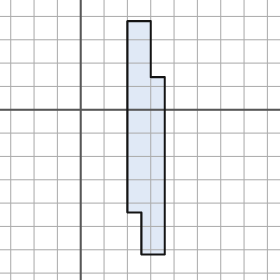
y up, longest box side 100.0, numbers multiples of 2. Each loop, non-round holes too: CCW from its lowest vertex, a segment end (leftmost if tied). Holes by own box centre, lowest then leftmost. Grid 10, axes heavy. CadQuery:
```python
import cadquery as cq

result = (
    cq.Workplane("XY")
    .moveTo(26.0, -62.0)
    .lineTo(36.0, -62.0)
    .lineTo(36.0, 14.0)
    .lineTo(30.0, 14.0)
    .lineTo(30.0, 38.0)
    .lineTo(20.0, 38.0)
    .lineTo(20.0, -44.0)
    .lineTo(26.0, -44.0)
    .close()
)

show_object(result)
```